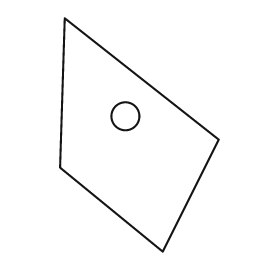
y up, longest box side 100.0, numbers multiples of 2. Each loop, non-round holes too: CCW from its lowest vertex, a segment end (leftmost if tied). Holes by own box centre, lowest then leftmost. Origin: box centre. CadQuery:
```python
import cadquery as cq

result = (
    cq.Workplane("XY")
    .moveTo(10.0, -50.0)
    .lineTo(34.0, -2.0)
    .lineTo(-32.0, 50.0)
    .lineTo(-34.0, -14.0)
    .close()
    .moveTo(-6.0, 8.0)
    .circle(6.0)
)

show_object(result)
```